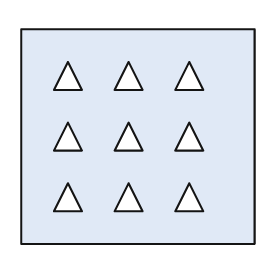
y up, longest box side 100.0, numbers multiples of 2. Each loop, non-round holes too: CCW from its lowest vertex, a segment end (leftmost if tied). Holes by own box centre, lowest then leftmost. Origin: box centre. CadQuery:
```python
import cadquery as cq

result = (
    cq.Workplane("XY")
    .moveTo(-50.0, -46.0)
    .lineTo(50.0, -46.0)
    .lineTo(50.0, 46.0)
    .lineTo(-50.0, 46.0)
    .close()
    .moveTo(-36.0, -32.0)
    .lineTo(-24.0, -32.0)
    .lineTo(-30.0, -20.0)
    .close()
    .moveTo(-10.0, -32.0)
    .lineTo(2.0, -32.0)
    .lineTo(-4.0, -20.0)
    .close()
    .moveTo(16.0, -32.0)
    .lineTo(28.0, -32.0)
    .lineTo(22.0, -20.0)
    .close()
    .moveTo(-36.0, -6.0)
    .lineTo(-24.0, -6.0)
    .lineTo(-30.0, 6.0)
    .close()
    .moveTo(-10.0, -6.0)
    .lineTo(2.0, -6.0)
    .lineTo(-4.0, 6.0)
    .close()
    .moveTo(16.0, -6.0)
    .lineTo(28.0, -6.0)
    .lineTo(22.0, 6.0)
    .close()
    .moveTo(-36.0, 20.0)
    .lineTo(-24.0, 20.0)
    .lineTo(-30.0, 32.0)
    .close()
    .moveTo(-10.0, 20.0)
    .lineTo(2.0, 20.0)
    .lineTo(-4.0, 32.0)
    .close()
    .moveTo(16.0, 20.0)
    .lineTo(28.0, 20.0)
    .lineTo(22.0, 32.0)
    .close()
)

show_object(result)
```